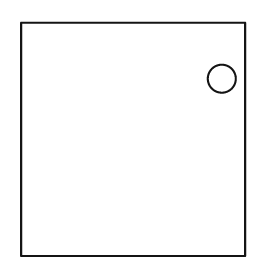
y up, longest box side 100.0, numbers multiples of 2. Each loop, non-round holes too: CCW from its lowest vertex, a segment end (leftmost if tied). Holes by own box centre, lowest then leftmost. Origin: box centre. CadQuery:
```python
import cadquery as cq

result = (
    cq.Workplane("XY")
    .moveTo(-48.0, -50.0)
    .lineTo(48.0, -50.0)
    .lineTo(48.0, 50.0)
    .lineTo(-48.0, 50.0)
    .close()
    .moveTo(38.0, 26.0)
    .circle(6.0)
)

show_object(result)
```